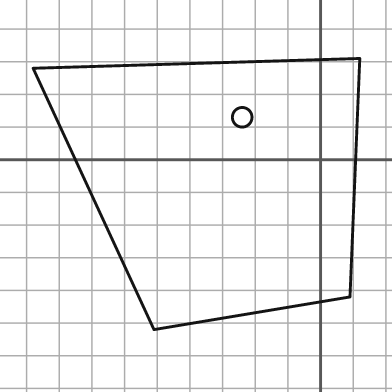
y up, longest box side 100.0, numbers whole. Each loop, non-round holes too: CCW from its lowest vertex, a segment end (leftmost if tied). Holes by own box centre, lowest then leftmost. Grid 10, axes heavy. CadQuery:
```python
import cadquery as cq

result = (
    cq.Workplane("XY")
    .moveTo(-51.0, -52.0)
    .lineTo(9.0, -42.0)
    .lineTo(12.0, 31.0)
    .lineTo(-88.0, 28.0)
    .close()
    .moveTo(-24.0, 13.0)
    .circle(3.0)
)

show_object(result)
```